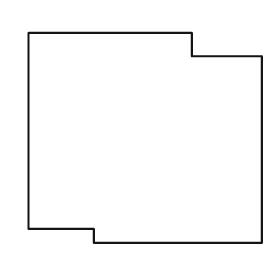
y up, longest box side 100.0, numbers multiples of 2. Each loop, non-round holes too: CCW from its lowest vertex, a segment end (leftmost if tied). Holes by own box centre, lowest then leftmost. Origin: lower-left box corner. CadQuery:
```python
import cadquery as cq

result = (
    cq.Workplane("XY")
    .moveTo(28.0, 0.0)
    .lineTo(100.0, 0.0)
    .lineTo(100.0, 80.0)
    .lineTo(70.0, 80.0)
    .lineTo(70.0, 90.0)
    .lineTo(0.0, 90.0)
    .lineTo(0.0, 6.0)
    .lineTo(28.0, 6.0)
    .close()
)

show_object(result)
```